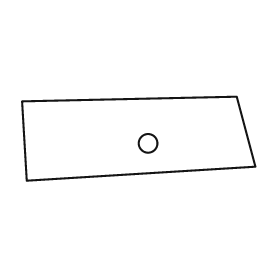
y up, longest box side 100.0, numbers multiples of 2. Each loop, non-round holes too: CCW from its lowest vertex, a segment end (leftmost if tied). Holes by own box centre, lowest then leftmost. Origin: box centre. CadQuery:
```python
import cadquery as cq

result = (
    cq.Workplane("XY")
    .moveTo(-48.0, -18.0)
    .lineTo(50.0, -12.0)
    .lineTo(42.0, 18.0)
    .lineTo(-50.0, 16.0)
    .close()
    .moveTo(4.0, -2.0)
    .circle(4.0)
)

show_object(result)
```